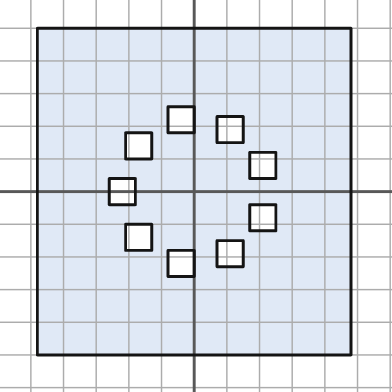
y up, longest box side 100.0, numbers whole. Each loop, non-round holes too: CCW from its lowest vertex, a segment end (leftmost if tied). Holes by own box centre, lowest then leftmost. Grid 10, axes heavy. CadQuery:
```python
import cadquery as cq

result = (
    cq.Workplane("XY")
    .moveTo(-48.0, -50.0)
    .lineTo(48.0, -50.0)
    .lineTo(48.0, 50.0)
    .lineTo(-48.0, 50.0)
    .close()
    .moveTo(-8.0, -26.0)
    .lineTo(0.0, -26.0)
    .lineTo(0.0, -18.0)
    .lineTo(-8.0, -18.0)
    .close()
    .moveTo(7.0, -23.0)
    .lineTo(15.0, -23.0)
    .lineTo(15.0, -15.0)
    .lineTo(7.0, -15.0)
    .close()
    .moveTo(-21.0, -18.0)
    .lineTo(-13.0, -18.0)
    .lineTo(-13.0, -10.0)
    .lineTo(-21.0, -10.0)
    .close()
    .moveTo(17.0, -12.0)
    .lineTo(25.0, -12.0)
    .lineTo(25.0, -4.0)
    .lineTo(17.0, -4.0)
    .close()
    .moveTo(-26.0, -4.0)
    .lineTo(-18.0, -4.0)
    .lineTo(-18.0, 4.0)
    .lineTo(-26.0, 4.0)
    .close()
    .moveTo(17.0, 4.0)
    .lineTo(25.0, 4.0)
    .lineTo(25.0, 12.0)
    .lineTo(17.0, 12.0)
    .close()
    .moveTo(-21.0, 10.0)
    .lineTo(-13.0, 10.0)
    .lineTo(-13.0, 18.0)
    .lineTo(-21.0, 18.0)
    .close()
    .moveTo(7.0, 15.0)
    .lineTo(15.0, 15.0)
    .lineTo(15.0, 23.0)
    .lineTo(7.0, 23.0)
    .close()
    .moveTo(-8.0, 18.0)
    .lineTo(0.0, 18.0)
    .lineTo(0.0, 26.0)
    .lineTo(-8.0, 26.0)
    .close()
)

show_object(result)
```